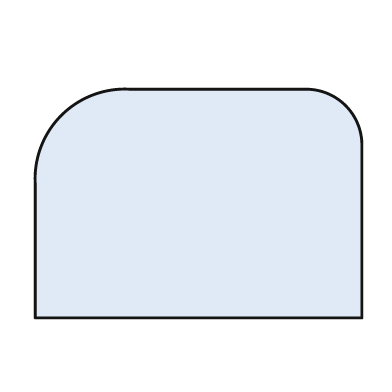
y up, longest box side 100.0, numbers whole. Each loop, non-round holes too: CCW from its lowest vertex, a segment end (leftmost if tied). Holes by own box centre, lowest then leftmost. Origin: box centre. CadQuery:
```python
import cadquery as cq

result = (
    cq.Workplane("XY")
    .moveTo(-50.0, -35.0)
    .lineTo(50.0, -35.0)
    .lineTo(50.0, 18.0)
    .threePointArc((45.0, 30.0), (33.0, 35.0))
    .lineTo(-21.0, 35.0)
    .threePointArc((-42.0, 27.0), (-50.0, 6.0))
    .close()
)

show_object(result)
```